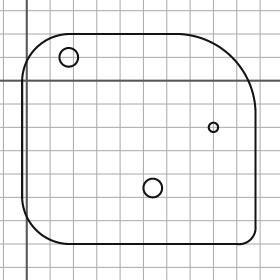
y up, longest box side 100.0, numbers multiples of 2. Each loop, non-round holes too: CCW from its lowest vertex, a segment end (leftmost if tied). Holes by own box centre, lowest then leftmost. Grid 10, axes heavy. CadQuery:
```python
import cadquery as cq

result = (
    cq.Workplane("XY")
    .moveTo(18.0, -70.0)
    .lineTo(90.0, -70.0)
    .threePointArc((96.0, -68.0), (98.0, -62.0))
    .lineTo(98.0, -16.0)
    .threePointArc((88.0, 10.0), (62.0, 20.0))
    .lineTo(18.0, 20.0)
    .threePointArc((4.0, 14.0), (-2.0, 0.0))
    .lineTo(-2.0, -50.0)
    .threePointArc((4.0, -64.0), (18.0, -70.0))
    .close()
    .moveTo(54.0, -46.0)
    .circle(4.0)
    .moveTo(80.0, -20.0)
    .circle(2.0)
    .moveTo(18.0, 10.0)
    .circle(4.0)
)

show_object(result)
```